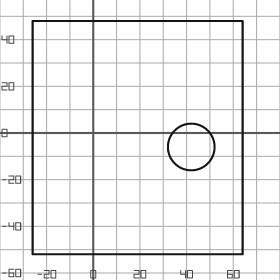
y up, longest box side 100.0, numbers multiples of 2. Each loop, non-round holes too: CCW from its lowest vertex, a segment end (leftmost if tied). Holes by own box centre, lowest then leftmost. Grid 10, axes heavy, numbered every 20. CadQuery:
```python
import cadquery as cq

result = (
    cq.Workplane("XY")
    .moveTo(-26.0, -52.0)
    .lineTo(64.0, -52.0)
    .lineTo(64.0, 48.0)
    .lineTo(-26.0, 48.0)
    .close()
    .moveTo(42.0, -6.0)
    .circle(10.0)
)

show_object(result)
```